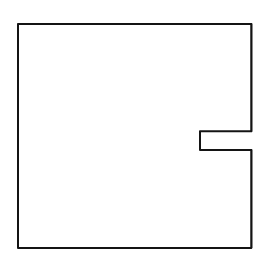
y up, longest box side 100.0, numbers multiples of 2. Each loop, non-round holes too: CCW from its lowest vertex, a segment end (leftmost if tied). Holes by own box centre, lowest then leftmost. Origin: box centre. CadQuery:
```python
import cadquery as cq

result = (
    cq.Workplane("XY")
    .moveTo(-50.0, -48.0)
    .lineTo(50.0, -48.0)
    .lineTo(50.0, -6.0)
    .lineTo(28.0, -6.0)
    .lineTo(28.0, 2.0)
    .lineTo(50.0, 2.0)
    .lineTo(50.0, 48.0)
    .lineTo(-50.0, 48.0)
    .close()
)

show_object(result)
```